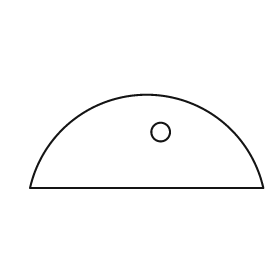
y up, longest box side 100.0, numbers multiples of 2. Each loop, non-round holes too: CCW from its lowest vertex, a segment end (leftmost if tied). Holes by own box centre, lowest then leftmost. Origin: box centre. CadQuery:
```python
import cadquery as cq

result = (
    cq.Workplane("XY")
    .moveTo(-50.0, -20.0)
    .lineTo(50.0, -20.0)
    .threePointArc((0.0, 20.0), (-50.0, -20.0))
    .close()
    .moveTo(6.0, 4.0)
    .circle(4.0)
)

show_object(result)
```